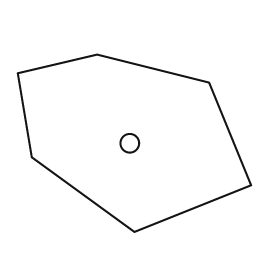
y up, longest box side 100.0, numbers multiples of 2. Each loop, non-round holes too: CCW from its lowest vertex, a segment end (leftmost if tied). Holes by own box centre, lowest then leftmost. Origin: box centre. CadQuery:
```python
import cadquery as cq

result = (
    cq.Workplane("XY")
    .moveTo(0.0, -38.0)
    .lineTo(50.0, -18.0)
    .lineTo(32.0, 26.0)
    .lineTo(-16.0, 38.0)
    .lineTo(-50.0, 30.0)
    .lineTo(-44.0, -6.0)
    .close()
    .moveTo(-2.0, 0.0)
    .circle(4.0)
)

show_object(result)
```